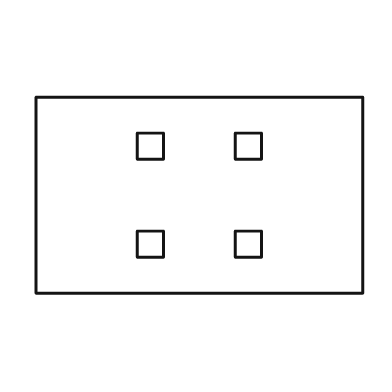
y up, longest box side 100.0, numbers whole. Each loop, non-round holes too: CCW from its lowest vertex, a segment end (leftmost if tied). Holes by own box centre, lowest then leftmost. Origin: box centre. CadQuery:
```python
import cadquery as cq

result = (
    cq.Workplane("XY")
    .moveTo(-50.0, -30.0)
    .lineTo(50.0, -30.0)
    .lineTo(50.0, 30.0)
    .lineTo(-50.0, 30.0)
    .close()
    .moveTo(-19.0, -19.0)
    .lineTo(-11.0, -19.0)
    .lineTo(-11.0, -11.0)
    .lineTo(-19.0, -11.0)
    .close()
    .moveTo(11.0, -19.0)
    .lineTo(19.0, -19.0)
    .lineTo(19.0, -11.0)
    .lineTo(11.0, -11.0)
    .close()
    .moveTo(-19.0, 11.0)
    .lineTo(-11.0, 11.0)
    .lineTo(-11.0, 19.0)
    .lineTo(-19.0, 19.0)
    .close()
    .moveTo(11.0, 11.0)
    .lineTo(19.0, 11.0)
    .lineTo(19.0, 19.0)
    .lineTo(11.0, 19.0)
    .close()
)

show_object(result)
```